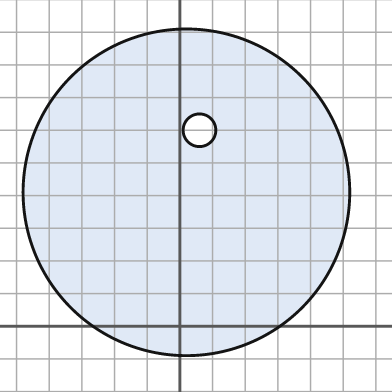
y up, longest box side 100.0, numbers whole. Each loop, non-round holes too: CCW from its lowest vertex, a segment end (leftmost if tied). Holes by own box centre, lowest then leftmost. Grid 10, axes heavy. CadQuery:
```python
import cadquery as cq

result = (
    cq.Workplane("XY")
    .moveTo(2.0, 41.0)
    .circle(50.0)
    .moveTo(6.0, 60.0)
    .circle(5.0)
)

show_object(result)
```